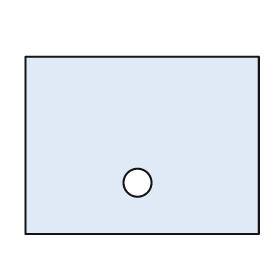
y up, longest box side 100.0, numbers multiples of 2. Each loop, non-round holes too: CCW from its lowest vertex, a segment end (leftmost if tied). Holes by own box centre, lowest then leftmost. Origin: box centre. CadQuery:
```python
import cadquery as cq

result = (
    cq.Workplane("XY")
    .moveTo(-50.0, -38.0)
    .lineTo(50.0, -38.0)
    .lineTo(50.0, 38.0)
    .lineTo(-50.0, 38.0)
    .close()
    .moveTo(-2.0, -16.0)
    .circle(6.0)
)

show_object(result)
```